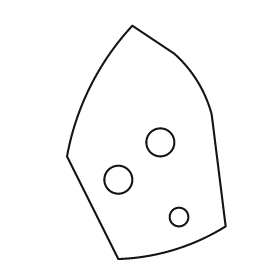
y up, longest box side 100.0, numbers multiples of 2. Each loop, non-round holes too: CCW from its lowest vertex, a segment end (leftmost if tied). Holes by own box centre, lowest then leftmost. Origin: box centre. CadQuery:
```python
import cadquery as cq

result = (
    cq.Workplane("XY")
    .moveTo(-12.0, -50.0)
    .threePointArc((12.0, -46.0), (34.0, -36.0))
    .lineTo(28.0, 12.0)
    .threePointArc((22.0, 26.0), (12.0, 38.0))
    .lineTo(-6.0, 50.0)
    .threePointArc((-24.0, 24.0), (-34.0, -6.0))
    .close()
    .moveTo(14.0, -32.0)
    .circle(4.0)
    .moveTo(-12.0, -16.0)
    .circle(6.0)
    .moveTo(6.0, 0.0)
    .circle(6.0)
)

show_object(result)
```